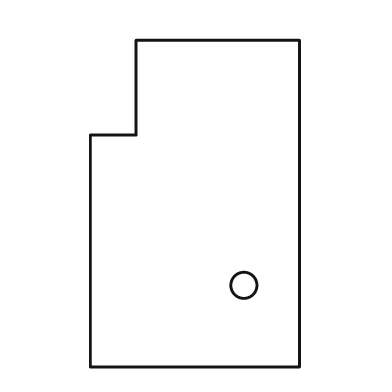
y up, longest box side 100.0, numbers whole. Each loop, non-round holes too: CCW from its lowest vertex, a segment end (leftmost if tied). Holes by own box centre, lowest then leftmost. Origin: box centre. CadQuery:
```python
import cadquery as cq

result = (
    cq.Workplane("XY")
    .moveTo(-32.0, -50.0)
    .lineTo(32.0, -50.0)
    .lineTo(32.0, 50.0)
    .lineTo(-18.0, 50.0)
    .lineTo(-18.0, 21.0)
    .lineTo(-32.0, 21.0)
    .close()
    .moveTo(15.0, -25.0)
    .circle(4.0)
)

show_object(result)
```